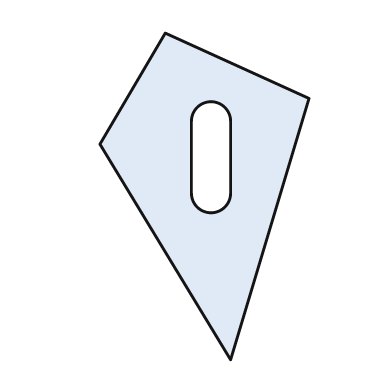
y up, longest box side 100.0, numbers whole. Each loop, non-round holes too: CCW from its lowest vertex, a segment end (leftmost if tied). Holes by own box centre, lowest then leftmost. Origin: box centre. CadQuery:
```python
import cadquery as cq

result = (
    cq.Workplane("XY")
    .moveTo(8.0, -50.0)
    .lineTo(32.0, 30.0)
    .lineTo(-12.0, 50.0)
    .lineTo(-32.0, 16.0)
    .close()
    .moveTo(-4.0, 1.0)
    .threePointArc((2.0, -5.0), (8.0, 1.0))
    .lineTo(8.0, 23.0)
    .threePointArc((2.0, 29.0), (-4.0, 23.0))
    .close()
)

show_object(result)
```